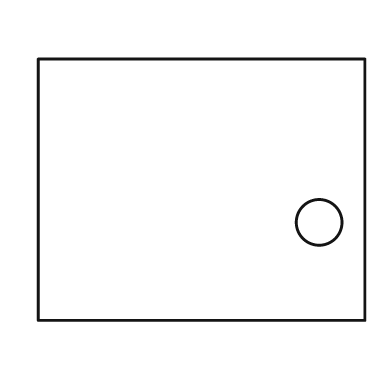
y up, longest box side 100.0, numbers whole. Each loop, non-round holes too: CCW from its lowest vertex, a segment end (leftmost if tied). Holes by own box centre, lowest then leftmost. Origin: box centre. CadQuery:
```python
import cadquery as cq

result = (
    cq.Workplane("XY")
    .moveTo(-50.0, -40.0)
    .lineTo(50.0, -40.0)
    .lineTo(50.0, 40.0)
    .lineTo(-50.0, 40.0)
    .close()
    .moveTo(36.0, -10.0)
    .circle(7.0)
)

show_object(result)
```